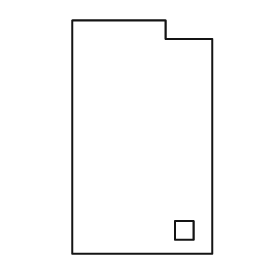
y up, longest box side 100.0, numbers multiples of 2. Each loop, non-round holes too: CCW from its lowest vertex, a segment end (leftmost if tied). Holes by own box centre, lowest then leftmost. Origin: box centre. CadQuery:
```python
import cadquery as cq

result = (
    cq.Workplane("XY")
    .moveTo(-30.0, -50.0)
    .lineTo(30.0, -50.0)
    .lineTo(30.0, 42.0)
    .lineTo(10.0, 42.0)
    .lineTo(10.0, 50.0)
    .lineTo(-30.0, 50.0)
    .close()
    .moveTo(14.0, -44.0)
    .lineTo(22.0, -44.0)
    .lineTo(22.0, -36.0)
    .lineTo(14.0, -36.0)
    .close()
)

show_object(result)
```